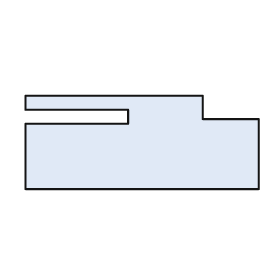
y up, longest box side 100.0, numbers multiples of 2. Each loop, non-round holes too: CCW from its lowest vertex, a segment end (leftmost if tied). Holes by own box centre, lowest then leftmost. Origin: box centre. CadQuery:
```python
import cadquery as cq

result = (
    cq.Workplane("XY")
    .moveTo(-50.0, -20.0)
    .lineTo(50.0, -20.0)
    .lineTo(50.0, 10.0)
    .lineTo(26.0, 10.0)
    .lineTo(26.0, 20.0)
    .lineTo(-50.0, 20.0)
    .lineTo(-50.0, 14.0)
    .lineTo(-6.0, 14.0)
    .lineTo(-6.0, 8.0)
    .lineTo(-50.0, 8.0)
    .close()
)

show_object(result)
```